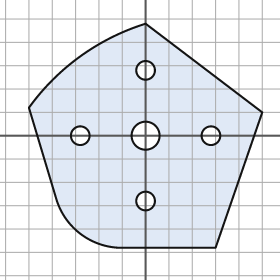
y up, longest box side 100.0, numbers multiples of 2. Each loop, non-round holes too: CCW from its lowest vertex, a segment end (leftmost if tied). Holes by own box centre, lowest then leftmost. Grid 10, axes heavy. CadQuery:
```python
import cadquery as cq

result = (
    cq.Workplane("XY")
    .moveTo(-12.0, -48.0)
    .lineTo(30.0, -48.0)
    .lineTo(50.0, 10.0)
    .lineTo(0.0, 48.0)
    .threePointArc((-28.0, 34.0), (-50.0, 12.0))
    .lineTo(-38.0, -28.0)
    .threePointArc((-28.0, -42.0), (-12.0, -48.0))
    .close()
    .moveTo(0.0, -28.0)
    .circle(4.0)
    .moveTo(-28.0, 0.0)
    .circle(4.0)
    .moveTo(0.0, 0.0)
    .circle(6.0)
    .moveTo(28.0, 0.0)
    .circle(4.0)
    .moveTo(0.0, 28.0)
    .circle(4.0)
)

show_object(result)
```